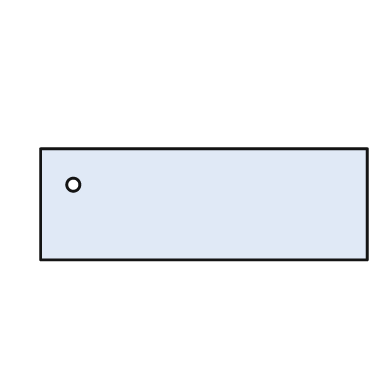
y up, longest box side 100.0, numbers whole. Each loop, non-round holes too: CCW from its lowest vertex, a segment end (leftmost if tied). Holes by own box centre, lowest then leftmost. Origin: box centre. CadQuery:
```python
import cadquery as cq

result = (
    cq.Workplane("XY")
    .moveTo(-50.0, -17.0)
    .lineTo(50.0, -17.0)
    .lineTo(50.0, 17.0)
    .lineTo(-50.0, 17.0)
    .close()
    .moveTo(-40.0, 6.0)
    .circle(2.0)
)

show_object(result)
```